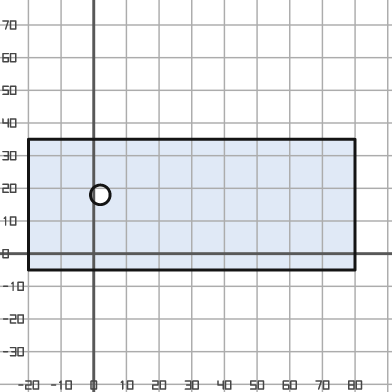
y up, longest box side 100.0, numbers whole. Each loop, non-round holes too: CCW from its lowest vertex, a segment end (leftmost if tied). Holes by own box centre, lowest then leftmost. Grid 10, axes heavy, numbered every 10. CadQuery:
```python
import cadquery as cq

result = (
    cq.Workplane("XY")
    .moveTo(-20.0, -5.0)
    .lineTo(80.0, -5.0)
    .lineTo(80.0, 35.0)
    .lineTo(-20.0, 35.0)
    .close()
    .moveTo(2.0, 18.0)
    .circle(3.0)
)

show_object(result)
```